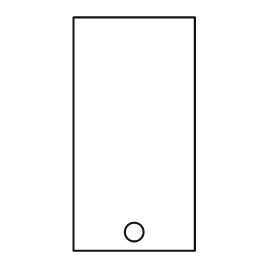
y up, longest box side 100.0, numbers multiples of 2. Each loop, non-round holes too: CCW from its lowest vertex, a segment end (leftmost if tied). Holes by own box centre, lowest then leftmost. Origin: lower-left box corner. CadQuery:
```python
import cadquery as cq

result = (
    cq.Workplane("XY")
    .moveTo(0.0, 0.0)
    .lineTo(52.0, 0.0)
    .lineTo(52.0, 100.0)
    .lineTo(0.0, 100.0)
    .close()
    .moveTo(26.0, 8.0)
    .circle(4.0)
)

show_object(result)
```